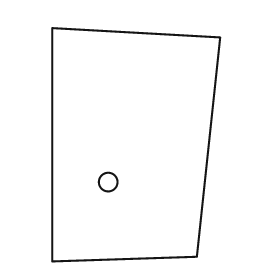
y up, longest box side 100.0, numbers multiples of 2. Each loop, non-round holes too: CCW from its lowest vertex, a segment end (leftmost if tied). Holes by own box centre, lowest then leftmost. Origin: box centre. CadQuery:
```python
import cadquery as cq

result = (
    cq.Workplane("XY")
    .moveTo(-36.0, -50.0)
    .lineTo(26.0, -48.0)
    .lineTo(36.0, 46.0)
    .lineTo(-36.0, 50.0)
    .close()
    .moveTo(-12.0, -16.0)
    .circle(4.0)
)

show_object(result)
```